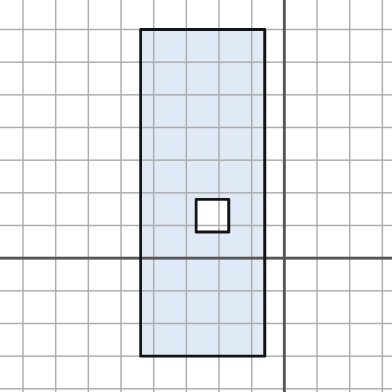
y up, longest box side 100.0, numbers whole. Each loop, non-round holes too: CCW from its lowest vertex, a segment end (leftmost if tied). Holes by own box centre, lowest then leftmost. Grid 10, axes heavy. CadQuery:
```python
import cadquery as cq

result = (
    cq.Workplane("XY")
    .moveTo(-44.0, -30.0)
    .lineTo(-6.0, -30.0)
    .lineTo(-6.0, 70.0)
    .lineTo(-44.0, 70.0)
    .close()
    .moveTo(-27.0, 8.0)
    .lineTo(-17.0, 8.0)
    .lineTo(-17.0, 18.0)
    .lineTo(-27.0, 18.0)
    .close()
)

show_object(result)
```